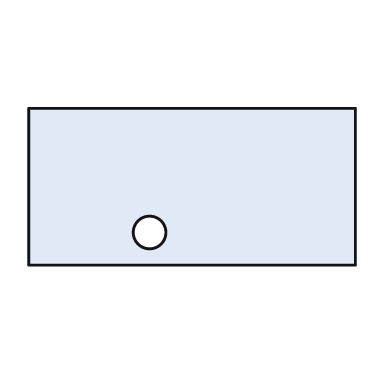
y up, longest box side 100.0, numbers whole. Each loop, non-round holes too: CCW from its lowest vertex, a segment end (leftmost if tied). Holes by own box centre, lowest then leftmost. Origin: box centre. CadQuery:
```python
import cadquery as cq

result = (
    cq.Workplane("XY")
    .moveTo(-50.0, -24.0)
    .lineTo(50.0, -24.0)
    .lineTo(50.0, 24.0)
    .lineTo(-50.0, 24.0)
    .close()
    .moveTo(-13.0, -14.0)
    .circle(5.0)
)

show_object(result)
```